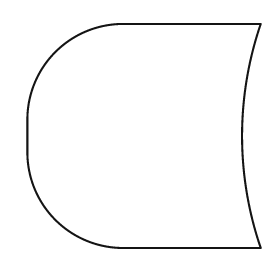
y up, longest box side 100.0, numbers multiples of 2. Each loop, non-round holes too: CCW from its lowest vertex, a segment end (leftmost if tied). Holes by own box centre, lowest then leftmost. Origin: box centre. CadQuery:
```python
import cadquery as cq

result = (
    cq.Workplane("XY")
    .moveTo(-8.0, -48.0)
    .lineTo(50.0, -48.0)
    .threePointArc((42.0, 0.0), (50.0, 48.0))
    .lineTo(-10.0, 48.0)
    .threePointArc((-38.0, 36.0), (-50.0, 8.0))
    .lineTo(-50.0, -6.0)
    .threePointArc((-38.0, -36.0), (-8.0, -48.0))
    .close()
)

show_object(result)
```